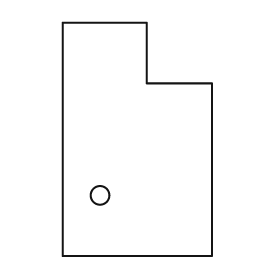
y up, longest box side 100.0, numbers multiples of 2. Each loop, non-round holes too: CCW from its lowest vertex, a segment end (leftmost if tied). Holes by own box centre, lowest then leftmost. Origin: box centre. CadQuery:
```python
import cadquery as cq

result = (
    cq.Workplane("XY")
    .moveTo(-32.0, -50.0)
    .lineTo(32.0, -50.0)
    .lineTo(32.0, 24.0)
    .lineTo(4.0, 24.0)
    .lineTo(4.0, 50.0)
    .lineTo(-32.0, 50.0)
    .close()
    .moveTo(-16.0, -24.0)
    .circle(4.0)
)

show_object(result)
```